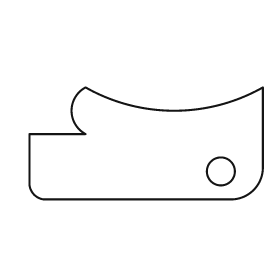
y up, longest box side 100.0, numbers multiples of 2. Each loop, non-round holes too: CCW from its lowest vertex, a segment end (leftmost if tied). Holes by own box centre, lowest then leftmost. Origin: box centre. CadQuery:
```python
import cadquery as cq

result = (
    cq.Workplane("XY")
    .moveTo(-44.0, -24.0)
    .lineTo(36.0, -24.0)
    .threePointArc((46.0, -20.0), (50.0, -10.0))
    .lineTo(50.0, 24.0)
    .threePointArc((12.0, 14.0), (-26.0, 24.0))
    .threePointArc((-32.0, 14.0), (-26.0, 4.0))
    .lineTo(-50.0, 4.0)
    .lineTo(-50.0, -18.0)
    .threePointArc((-48.0, -22.0), (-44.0, -24.0))
    .close()
    .moveTo(32.0, -12.0)
    .circle(6.0)
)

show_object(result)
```